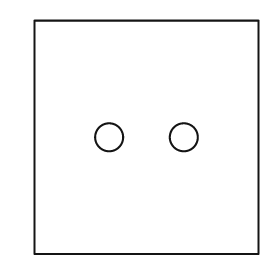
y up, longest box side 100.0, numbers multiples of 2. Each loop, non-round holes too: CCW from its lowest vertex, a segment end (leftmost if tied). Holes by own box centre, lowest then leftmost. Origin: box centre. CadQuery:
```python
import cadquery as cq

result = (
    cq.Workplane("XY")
    .moveTo(-48.0, -50.0)
    .lineTo(48.0, -50.0)
    .lineTo(48.0, 50.0)
    .lineTo(-48.0, 50.0)
    .close()
    .moveTo(-16.0, 0.0)
    .circle(6.0)
    .moveTo(16.0, 0.0)
    .circle(6.0)
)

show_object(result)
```